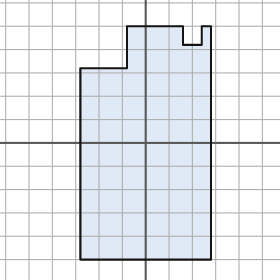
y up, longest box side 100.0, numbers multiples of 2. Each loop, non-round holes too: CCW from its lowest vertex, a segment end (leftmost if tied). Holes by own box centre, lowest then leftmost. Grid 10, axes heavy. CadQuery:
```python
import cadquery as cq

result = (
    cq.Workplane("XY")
    .moveTo(-28.0, -50.0)
    .lineTo(28.0, -50.0)
    .lineTo(28.0, 50.0)
    .lineTo(24.0, 50.0)
    .lineTo(24.0, 42.0)
    .lineTo(16.0, 42.0)
    .lineTo(16.0, 50.0)
    .lineTo(-8.0, 50.0)
    .lineTo(-8.0, 32.0)
    .lineTo(-28.0, 32.0)
    .close()
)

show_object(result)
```